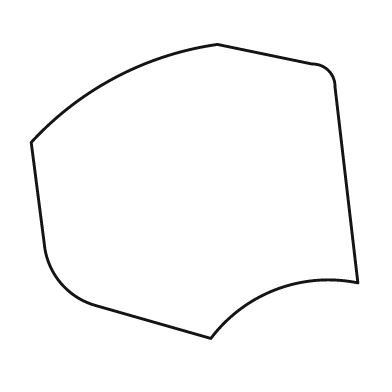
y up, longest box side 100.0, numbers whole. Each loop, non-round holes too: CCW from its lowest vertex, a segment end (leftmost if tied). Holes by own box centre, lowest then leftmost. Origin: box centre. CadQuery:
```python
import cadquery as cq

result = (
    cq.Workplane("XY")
    .moveTo(5.0, -45.0)
    .threePointArc((25.0, -30.0), (50.0, -28.0))
    .lineTo(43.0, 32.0)
    .threePointArc((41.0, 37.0), (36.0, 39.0))
    .lineTo(7.0, 45.0)
    .threePointArc((-24.0, 35.0), (-50.0, 15.0))
    .lineTo(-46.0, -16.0)
    .threePointArc((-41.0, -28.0), (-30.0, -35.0))
    .close()
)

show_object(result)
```